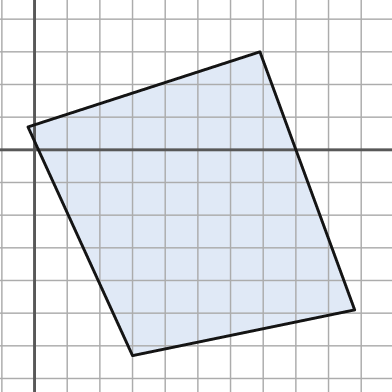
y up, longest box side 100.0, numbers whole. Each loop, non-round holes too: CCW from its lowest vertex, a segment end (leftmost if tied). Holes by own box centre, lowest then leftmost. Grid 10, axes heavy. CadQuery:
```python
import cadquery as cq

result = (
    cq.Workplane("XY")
    .moveTo(30.0, -63.0)
    .lineTo(98.0, -49.0)
    .lineTo(69.0, 30.0)
    .lineTo(-2.0, 7.0)
    .close()
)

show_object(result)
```